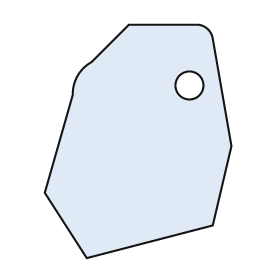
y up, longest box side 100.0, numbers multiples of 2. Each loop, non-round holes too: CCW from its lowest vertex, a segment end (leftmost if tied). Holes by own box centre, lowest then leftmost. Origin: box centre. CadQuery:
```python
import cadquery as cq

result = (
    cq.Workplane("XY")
    .moveTo(-22.0, -50.0)
    .lineTo(32.0, -36.0)
    .lineTo(40.0, -2.0)
    .lineTo(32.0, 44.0)
    .threePointArc((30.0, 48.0), (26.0, 50.0))
    .lineTo(-4.0, 50.0)
    .lineTo(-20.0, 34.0)
    .threePointArc((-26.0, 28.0), (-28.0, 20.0))
    .lineTo(-40.0, -22.0)
    .close()
    .moveTo(22.0, 24.0)
    .circle(6.0)
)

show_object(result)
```